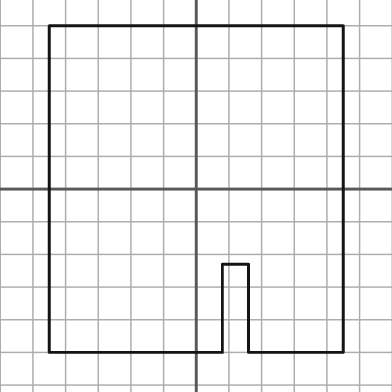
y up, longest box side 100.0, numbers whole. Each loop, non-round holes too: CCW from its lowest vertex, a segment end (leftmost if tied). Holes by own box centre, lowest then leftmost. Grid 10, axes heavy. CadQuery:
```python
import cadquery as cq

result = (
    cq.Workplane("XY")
    .moveTo(-45.0, -50.0)
    .lineTo(8.0, -50.0)
    .lineTo(8.0, -23.0)
    .lineTo(16.0, -23.0)
    .lineTo(16.0, -50.0)
    .lineTo(45.0, -50.0)
    .lineTo(45.0, 50.0)
    .lineTo(-45.0, 50.0)
    .close()
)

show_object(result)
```